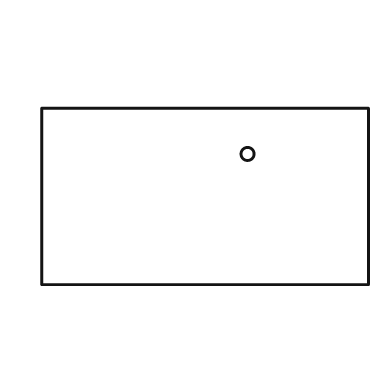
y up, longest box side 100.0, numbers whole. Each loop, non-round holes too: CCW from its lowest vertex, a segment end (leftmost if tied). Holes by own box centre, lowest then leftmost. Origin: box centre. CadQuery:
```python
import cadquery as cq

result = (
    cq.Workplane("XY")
    .moveTo(-50.0, -27.0)
    .lineTo(50.0, -27.0)
    .lineTo(50.0, 27.0)
    .lineTo(-50.0, 27.0)
    .close()
    .moveTo(13.0, 13.0)
    .circle(2.0)
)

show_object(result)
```